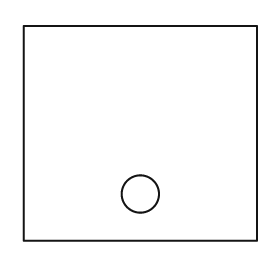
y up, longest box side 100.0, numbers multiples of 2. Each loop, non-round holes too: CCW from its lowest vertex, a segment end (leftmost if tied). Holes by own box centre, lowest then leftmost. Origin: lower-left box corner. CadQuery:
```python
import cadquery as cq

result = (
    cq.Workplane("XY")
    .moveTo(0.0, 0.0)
    .lineTo(100.0, 0.0)
    .lineTo(100.0, 92.0)
    .lineTo(0.0, 92.0)
    .close()
    .moveTo(50.0, 20.0)
    .circle(8.0)
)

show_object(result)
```